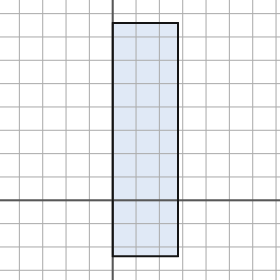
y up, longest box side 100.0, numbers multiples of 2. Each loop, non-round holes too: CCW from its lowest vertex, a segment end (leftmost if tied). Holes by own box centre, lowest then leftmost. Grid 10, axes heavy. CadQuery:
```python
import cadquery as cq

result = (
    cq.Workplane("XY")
    .moveTo(0.0, -24.0)
    .lineTo(28.0, -24.0)
    .lineTo(28.0, 76.0)
    .lineTo(0.0, 76.0)
    .close()
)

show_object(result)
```